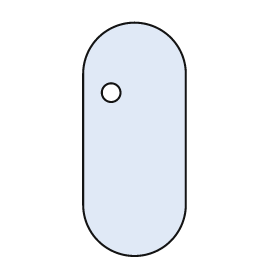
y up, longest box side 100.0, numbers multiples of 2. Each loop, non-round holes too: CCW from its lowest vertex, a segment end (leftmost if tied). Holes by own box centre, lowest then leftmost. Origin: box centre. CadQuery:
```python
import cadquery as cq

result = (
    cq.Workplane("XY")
    .moveTo(-22.0, -28.0)
    .threePointArc((0.0, -50.0), (22.0, -28.0))
    .lineTo(22.0, 28.0)
    .threePointArc((0.0, 50.0), (-22.0, 28.0))
    .close()
    .moveTo(-10.0, 20.0)
    .circle(4.0)
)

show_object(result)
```